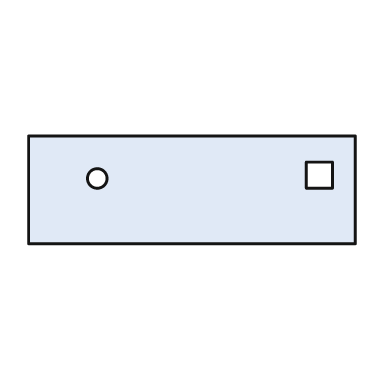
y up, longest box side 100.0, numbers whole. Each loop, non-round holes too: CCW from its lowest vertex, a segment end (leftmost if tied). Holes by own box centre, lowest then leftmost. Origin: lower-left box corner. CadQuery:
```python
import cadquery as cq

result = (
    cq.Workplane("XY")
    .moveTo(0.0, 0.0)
    .lineTo(100.0, 0.0)
    .lineTo(100.0, 33.0)
    .lineTo(0.0, 33.0)
    .close()
    .moveTo(21.0, 20.0)
    .circle(3.0)
    .moveTo(85.0, 17.0)
    .lineTo(93.0, 17.0)
    .lineTo(93.0, 25.0)
    .lineTo(85.0, 25.0)
    .close()
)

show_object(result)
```